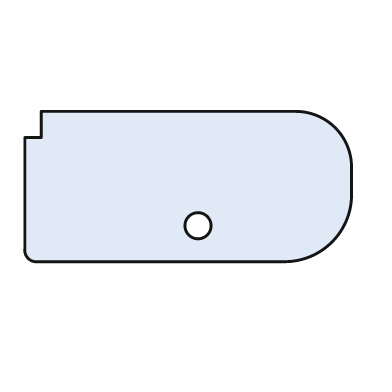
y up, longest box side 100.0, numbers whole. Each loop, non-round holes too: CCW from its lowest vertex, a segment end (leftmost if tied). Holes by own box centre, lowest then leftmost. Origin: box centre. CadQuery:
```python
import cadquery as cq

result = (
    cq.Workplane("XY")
    .moveTo(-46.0, -23.0)
    .lineTo(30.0, -23.0)
    .threePointArc((44.0, -17.0), (50.0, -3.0))
    .lineTo(50.0, 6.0)
    .threePointArc((45.0, 18.0), (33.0, 23.0))
    .lineTo(-45.0, 23.0)
    .lineTo(-45.0, 15.0)
    .lineTo(-50.0, 15.0)
    .lineTo(-50.0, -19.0)
    .threePointArc((-49.0, -22.0), (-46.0, -23.0))
    .close()
    .moveTo(3.0, -12.0)
    .circle(4.0)
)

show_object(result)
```